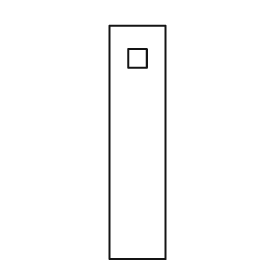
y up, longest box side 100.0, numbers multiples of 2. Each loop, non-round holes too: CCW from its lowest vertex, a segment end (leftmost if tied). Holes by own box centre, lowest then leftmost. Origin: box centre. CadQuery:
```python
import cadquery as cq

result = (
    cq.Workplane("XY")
    .moveTo(-12.0, -50.0)
    .lineTo(12.0, -50.0)
    .lineTo(12.0, 50.0)
    .lineTo(-12.0, 50.0)
    .close()
    .moveTo(-4.0, 32.0)
    .lineTo(4.0, 32.0)
    .lineTo(4.0, 40.0)
    .lineTo(-4.0, 40.0)
    .close()
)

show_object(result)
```